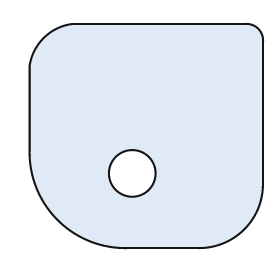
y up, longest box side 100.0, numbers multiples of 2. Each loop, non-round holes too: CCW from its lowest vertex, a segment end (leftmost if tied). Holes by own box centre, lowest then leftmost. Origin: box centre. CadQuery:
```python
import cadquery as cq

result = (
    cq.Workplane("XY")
    .moveTo(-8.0, -48.0)
    .lineTo(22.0, -48.0)
    .threePointArc((42.0, -40.0), (50.0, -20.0))
    .lineTo(50.0, 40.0)
    .threePointArc((48.0, 46.0), (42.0, 48.0))
    .lineTo(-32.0, 48.0)
    .threePointArc((-44.0, 42.0), (-50.0, 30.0))
    .lineTo(-50.0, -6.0)
    .threePointArc((-38.0, -36.0), (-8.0, -48.0))
    .close()
    .moveTo(-6.0, -16.0)
    .circle(10.0)
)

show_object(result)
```